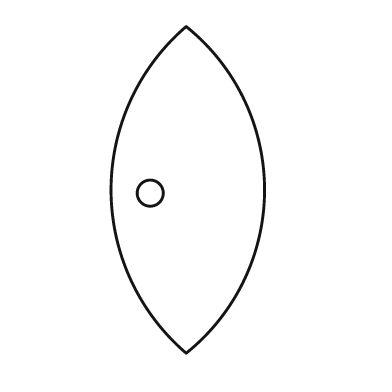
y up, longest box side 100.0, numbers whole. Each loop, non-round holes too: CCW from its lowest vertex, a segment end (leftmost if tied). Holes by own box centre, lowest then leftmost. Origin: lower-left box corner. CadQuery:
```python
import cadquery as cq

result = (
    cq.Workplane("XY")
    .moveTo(23.0, 0.0)
    .threePointArc((47.0, 50.0), (23.0, 100.0))
    .threePointArc((0.0, 50.0), (23.0, 0.0))
    .close()
    .moveTo(12.0, 49.0)
    .circle(4.0)
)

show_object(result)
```